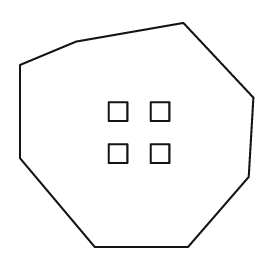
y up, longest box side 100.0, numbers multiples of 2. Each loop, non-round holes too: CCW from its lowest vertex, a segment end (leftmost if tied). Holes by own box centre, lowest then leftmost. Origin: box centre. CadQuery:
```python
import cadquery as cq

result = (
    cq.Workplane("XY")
    .moveTo(-18.0, -48.0)
    .lineTo(22.0, -48.0)
    .lineTo(48.0, -18.0)
    .lineTo(50.0, 16.0)
    .lineTo(20.0, 48.0)
    .lineTo(-26.0, 40.0)
    .lineTo(-50.0, 30.0)
    .lineTo(-50.0, -10.0)
    .close()
    .moveTo(-12.0, -12.0)
    .lineTo(-4.0, -12.0)
    .lineTo(-4.0, -4.0)
    .lineTo(-12.0, -4.0)
    .close()
    .moveTo(6.0, -12.0)
    .lineTo(14.0, -12.0)
    .lineTo(14.0, -4.0)
    .lineTo(6.0, -4.0)
    .close()
    .moveTo(-12.0, 6.0)
    .lineTo(-4.0, 6.0)
    .lineTo(-4.0, 14.0)
    .lineTo(-12.0, 14.0)
    .close()
    .moveTo(6.0, 6.0)
    .lineTo(14.0, 6.0)
    .lineTo(14.0, 14.0)
    .lineTo(6.0, 14.0)
    .close()
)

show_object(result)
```